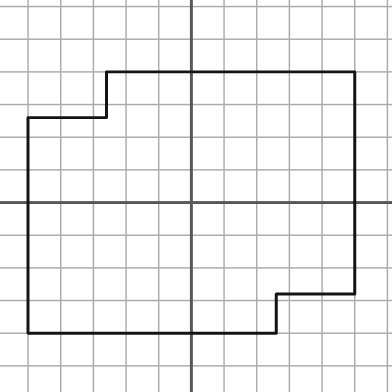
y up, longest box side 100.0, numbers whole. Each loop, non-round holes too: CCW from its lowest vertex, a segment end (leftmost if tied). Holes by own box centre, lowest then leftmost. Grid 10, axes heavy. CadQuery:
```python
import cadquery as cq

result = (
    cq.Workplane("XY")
    .moveTo(-50.0, -40.0)
    .lineTo(26.0, -40.0)
    .lineTo(26.0, -28.0)
    .lineTo(50.0, -28.0)
    .lineTo(50.0, 40.0)
    .lineTo(-26.0, 40.0)
    .lineTo(-26.0, 26.0)
    .lineTo(-50.0, 26.0)
    .close()
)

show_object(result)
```